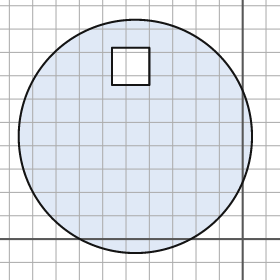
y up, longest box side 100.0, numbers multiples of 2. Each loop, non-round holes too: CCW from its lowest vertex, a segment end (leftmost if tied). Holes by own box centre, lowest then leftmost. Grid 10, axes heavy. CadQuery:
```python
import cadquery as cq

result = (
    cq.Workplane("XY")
    .moveTo(-46.0, 44.0)
    .circle(50.0)
    .moveTo(-56.0, 66.0)
    .lineTo(-40.0, 66.0)
    .lineTo(-40.0, 82.0)
    .lineTo(-56.0, 82.0)
    .close()
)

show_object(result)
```